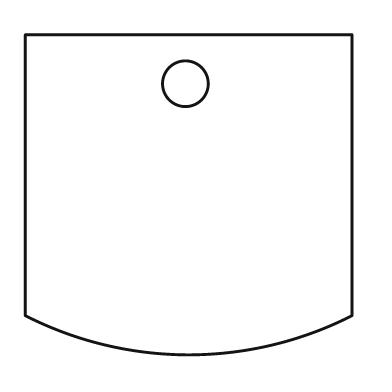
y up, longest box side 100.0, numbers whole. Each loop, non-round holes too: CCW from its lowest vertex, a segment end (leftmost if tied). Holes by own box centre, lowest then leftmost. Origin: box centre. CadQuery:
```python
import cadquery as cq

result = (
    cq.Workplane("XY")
    .moveTo(-50.0, -37.0)
    .threePointArc((0.0, -49.0), (50.0, -37.0))
    .lineTo(50.0, 49.0)
    .lineTo(-50.0, 49.0)
    .close()
    .moveTo(-1.0, 34.0)
    .circle(7.0)
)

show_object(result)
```